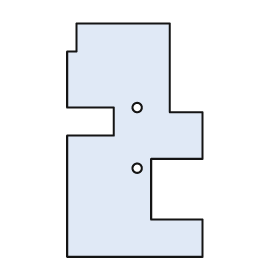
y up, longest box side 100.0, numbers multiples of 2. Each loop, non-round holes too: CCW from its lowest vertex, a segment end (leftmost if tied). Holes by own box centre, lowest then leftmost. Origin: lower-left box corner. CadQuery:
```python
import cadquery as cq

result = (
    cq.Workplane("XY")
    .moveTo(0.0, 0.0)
    .lineTo(58.0, 0.0)
    .lineTo(58.0, 16.0)
    .lineTo(36.0, 16.0)
    .lineTo(36.0, 42.0)
    .lineTo(58.0, 42.0)
    .lineTo(58.0, 62.0)
    .lineTo(44.0, 62.0)
    .lineTo(44.0, 100.0)
    .lineTo(4.0, 100.0)
    .lineTo(4.0, 88.0)
    .lineTo(0.0, 88.0)
    .lineTo(0.0, 64.0)
    .lineTo(20.0, 64.0)
    .lineTo(20.0, 52.0)
    .lineTo(0.0, 52.0)
    .close()
    .moveTo(30.0, 38.0)
    .circle(2.0)
    .moveTo(30.0, 64.0)
    .circle(2.0)
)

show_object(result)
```